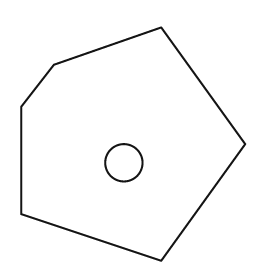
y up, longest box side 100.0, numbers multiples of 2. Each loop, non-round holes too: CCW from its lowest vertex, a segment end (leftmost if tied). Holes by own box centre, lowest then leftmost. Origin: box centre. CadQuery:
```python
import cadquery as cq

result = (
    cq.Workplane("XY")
    .moveTo(12.0, -50.0)
    .lineTo(48.0, 0.0)
    .lineTo(12.0, 50.0)
    .lineTo(-34.0, 34.0)
    .lineTo(-48.0, 16.0)
    .lineTo(-48.0, -30.0)
    .close()
    .moveTo(-4.0, -8.0)
    .circle(8.0)
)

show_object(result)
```